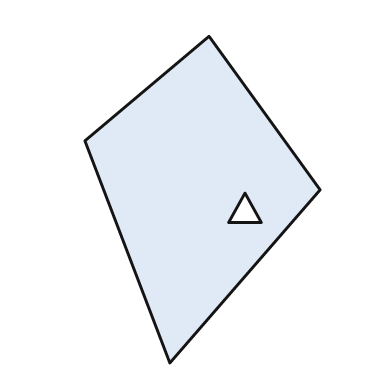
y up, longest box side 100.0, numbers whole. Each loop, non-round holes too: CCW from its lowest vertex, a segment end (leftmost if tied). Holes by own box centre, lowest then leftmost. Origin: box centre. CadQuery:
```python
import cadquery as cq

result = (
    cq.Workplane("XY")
    .moveTo(-10.0, -50.0)
    .lineTo(36.0, 3.0)
    .lineTo(2.0, 50.0)
    .lineTo(-36.0, 18.0)
    .close()
    .moveTo(8.0, -7.0)
    .lineTo(18.0, -7.0)
    .lineTo(13.0, 2.0)
    .close()
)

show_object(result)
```